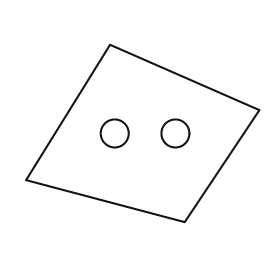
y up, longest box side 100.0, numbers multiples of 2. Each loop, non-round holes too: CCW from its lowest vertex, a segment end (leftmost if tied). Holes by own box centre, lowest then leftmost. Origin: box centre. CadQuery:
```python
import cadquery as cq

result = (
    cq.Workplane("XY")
    .moveTo(18.0, -38.0)
    .lineTo(50.0, 10.0)
    .lineTo(-14.0, 38.0)
    .lineTo(-50.0, -20.0)
    .close()
    .moveTo(-12.0, 0.0)
    .circle(6.0)
    .moveTo(14.0, 0.0)
    .circle(6.0)
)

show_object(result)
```